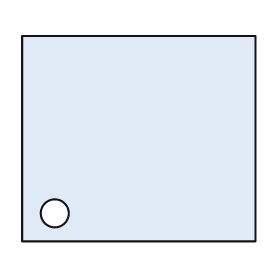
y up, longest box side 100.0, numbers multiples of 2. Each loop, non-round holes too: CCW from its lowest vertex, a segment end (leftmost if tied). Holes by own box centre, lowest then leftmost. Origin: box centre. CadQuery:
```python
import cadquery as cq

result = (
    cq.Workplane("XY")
    .moveTo(-50.0, -44.0)
    .lineTo(50.0, -44.0)
    .lineTo(50.0, 44.0)
    .lineTo(-50.0, 44.0)
    .close()
    .moveTo(-36.0, -32.0)
    .circle(6.0)
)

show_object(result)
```